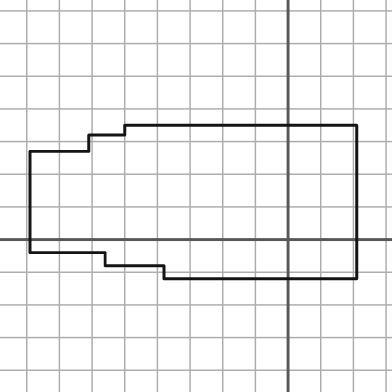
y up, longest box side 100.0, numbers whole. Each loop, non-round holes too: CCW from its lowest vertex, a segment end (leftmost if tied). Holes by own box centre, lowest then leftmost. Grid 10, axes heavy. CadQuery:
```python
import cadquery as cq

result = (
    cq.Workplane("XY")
    .moveTo(-38.0, -12.0)
    .lineTo(21.0, -12.0)
    .lineTo(21.0, 35.0)
    .lineTo(-50.0, 35.0)
    .lineTo(-50.0, 32.0)
    .lineTo(-61.0, 32.0)
    .lineTo(-61.0, 27.0)
    .lineTo(-79.0, 27.0)
    .lineTo(-79.0, -4.0)
    .lineTo(-56.0, -4.0)
    .lineTo(-56.0, -8.0)
    .lineTo(-38.0, -8.0)
    .close()
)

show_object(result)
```